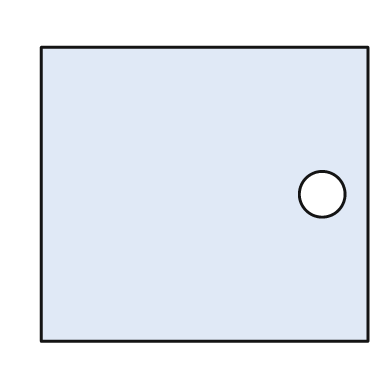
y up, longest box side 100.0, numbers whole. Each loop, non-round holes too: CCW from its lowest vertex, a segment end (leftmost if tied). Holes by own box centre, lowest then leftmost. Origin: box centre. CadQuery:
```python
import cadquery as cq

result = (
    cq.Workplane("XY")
    .moveTo(-50.0, -45.0)
    .lineTo(50.0, -45.0)
    .lineTo(50.0, 45.0)
    .lineTo(-50.0, 45.0)
    .close()
    .moveTo(36.0, 0.0)
    .circle(7.0)
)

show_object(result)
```